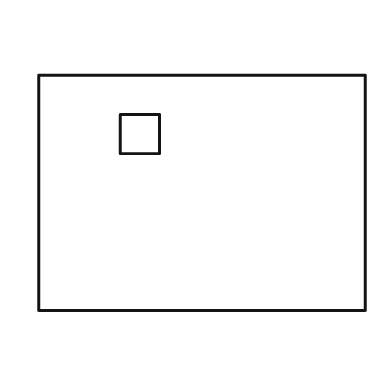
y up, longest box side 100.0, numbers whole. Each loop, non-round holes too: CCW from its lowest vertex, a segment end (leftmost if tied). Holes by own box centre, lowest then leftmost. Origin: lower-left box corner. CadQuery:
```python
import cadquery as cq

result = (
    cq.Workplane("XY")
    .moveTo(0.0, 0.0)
    .lineTo(100.0, 0.0)
    .lineTo(100.0, 72.0)
    .lineTo(0.0, 72.0)
    .close()
    .moveTo(25.0, 48.0)
    .lineTo(37.0, 48.0)
    .lineTo(37.0, 60.0)
    .lineTo(25.0, 60.0)
    .close()
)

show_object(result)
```